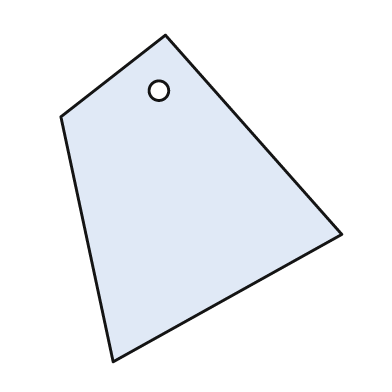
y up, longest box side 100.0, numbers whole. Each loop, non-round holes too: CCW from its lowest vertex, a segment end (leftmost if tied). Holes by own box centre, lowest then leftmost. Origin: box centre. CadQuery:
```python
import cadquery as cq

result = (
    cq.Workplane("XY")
    .moveTo(-27.0, -50.0)
    .lineTo(43.0, -11.0)
    .lineTo(-11.0, 50.0)
    .lineTo(-43.0, 25.0)
    .close()
    .moveTo(-13.0, 33.0)
    .circle(3.0)
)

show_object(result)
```